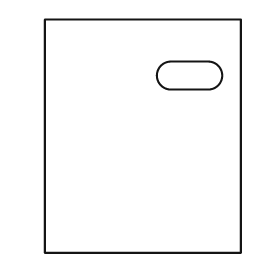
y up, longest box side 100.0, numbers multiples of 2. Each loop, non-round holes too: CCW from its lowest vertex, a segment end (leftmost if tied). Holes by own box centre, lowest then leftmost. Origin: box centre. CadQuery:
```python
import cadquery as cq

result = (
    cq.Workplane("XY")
    .moveTo(-42.0, -50.0)
    .lineTo(42.0, -50.0)
    .lineTo(42.0, 50.0)
    .lineTo(-42.0, 50.0)
    .close()
    .moveTo(12.0, 20.0)
    .lineTo(28.0, 20.0)
    .threePointArc((34.0, 26.0), (28.0, 32.0))
    .lineTo(12.0, 32.0)
    .threePointArc((6.0, 26.0), (12.0, 20.0))
    .close()
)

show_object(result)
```